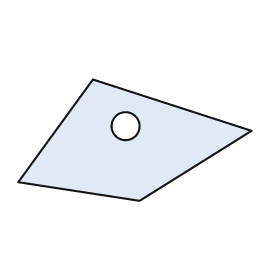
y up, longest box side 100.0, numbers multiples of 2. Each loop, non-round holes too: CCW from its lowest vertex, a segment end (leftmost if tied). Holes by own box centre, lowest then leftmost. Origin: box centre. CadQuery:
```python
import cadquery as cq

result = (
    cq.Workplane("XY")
    .moveTo(2.0, -26.0)
    .lineTo(50.0, 4.0)
    .lineTo(-18.0, 26.0)
    .lineTo(-50.0, -18.0)
    .close()
    .moveTo(-4.0, 6.0)
    .circle(6.0)
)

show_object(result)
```